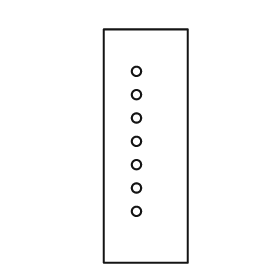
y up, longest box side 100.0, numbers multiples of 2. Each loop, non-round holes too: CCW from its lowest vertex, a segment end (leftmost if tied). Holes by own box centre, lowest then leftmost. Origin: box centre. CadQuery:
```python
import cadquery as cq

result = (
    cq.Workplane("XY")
    .moveTo(-18.0, -50.0)
    .lineTo(18.0, -50.0)
    .lineTo(18.0, 50.0)
    .lineTo(-18.0, 50.0)
    .close()
    .moveTo(-4.0, -28.0)
    .circle(2.0)
    .moveTo(-4.0, -18.0)
    .circle(2.0)
    .moveTo(-4.0, -8.0)
    .circle(2.0)
    .moveTo(-4.0, 2.0)
    .circle(2.0)
    .moveTo(-4.0, 12.0)
    .circle(2.0)
    .moveTo(-4.0, 22.0)
    .circle(2.0)
    .moveTo(-4.0, 32.0)
    .circle(2.0)
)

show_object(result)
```